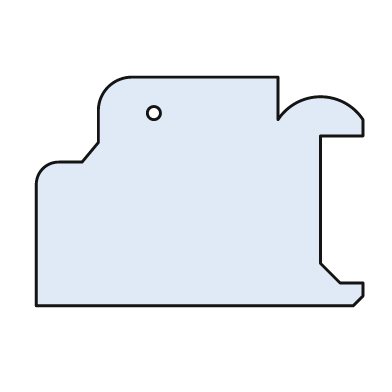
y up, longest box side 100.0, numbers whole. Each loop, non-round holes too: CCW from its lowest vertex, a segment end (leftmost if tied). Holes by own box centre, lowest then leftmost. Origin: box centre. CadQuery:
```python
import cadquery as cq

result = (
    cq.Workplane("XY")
    .moveTo(-50.0, -35.0)
    .lineTo(47.0, -35.0)
    .lineTo(50.0, -32.0)
    .lineTo(50.0, -28.0)
    .lineTo(43.0, -28.0)
    .lineTo(37.0, -22.0)
    .lineTo(37.0, 17.0)
    .lineTo(50.0, 17.0)
    .lineTo(50.0, 22.0)
    .threePointArc((37.0, 29.0), (24.0, 22.0))
    .lineTo(24.0, 35.0)
    .lineTo(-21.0, 35.0)
    .threePointArc((-28.0, 32.0), (-31.0, 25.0))
    .lineTo(-31.0, 15.0)
    .lineTo(-36.0, 9.0)
    .lineTo(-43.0, 9.0)
    .threePointArc((-48.0, 7.0), (-50.0, 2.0))
    .close()
    .moveTo(-14.0, 24.0)
    .circle(2.0)
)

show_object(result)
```